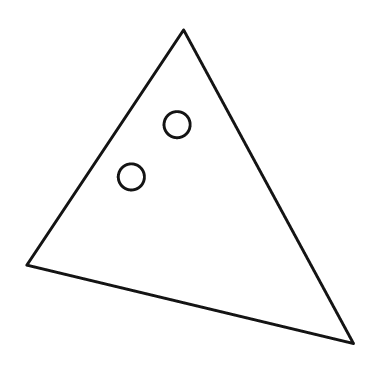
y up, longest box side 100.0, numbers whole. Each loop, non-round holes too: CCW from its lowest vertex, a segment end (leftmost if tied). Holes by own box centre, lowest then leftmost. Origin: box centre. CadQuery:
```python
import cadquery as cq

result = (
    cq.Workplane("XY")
    .moveTo(50.0, -48.0)
    .lineTo(-2.0, 48.0)
    .lineTo(-50.0, -24.0)
    .close()
    .moveTo(-18.0, 3.0)
    .circle(4.0)
    .moveTo(-4.0, 19.0)
    .circle(4.0)
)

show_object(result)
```